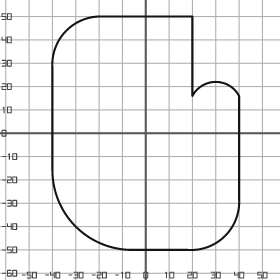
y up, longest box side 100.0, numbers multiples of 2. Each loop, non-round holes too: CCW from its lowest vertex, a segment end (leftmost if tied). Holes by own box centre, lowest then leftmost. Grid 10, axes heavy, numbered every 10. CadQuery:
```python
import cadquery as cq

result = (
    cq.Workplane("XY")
    .moveTo(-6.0, -50.0)
    .lineTo(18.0, -50.0)
    .threePointArc((34.0, -44.0), (40.0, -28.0))
    .lineTo(40.0, 16.0)
    .threePointArc((30.0, 22.0), (20.0, 16.0))
    .lineTo(20.0, 50.0)
    .lineTo(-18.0, 50.0)
    .threePointArc((-34.0, 44.0), (-40.0, 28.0))
    .lineTo(-40.0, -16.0)
    .threePointArc((-30.0, -40.0), (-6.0, -50.0))
    .close()
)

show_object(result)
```